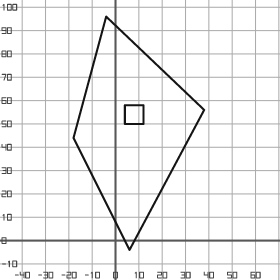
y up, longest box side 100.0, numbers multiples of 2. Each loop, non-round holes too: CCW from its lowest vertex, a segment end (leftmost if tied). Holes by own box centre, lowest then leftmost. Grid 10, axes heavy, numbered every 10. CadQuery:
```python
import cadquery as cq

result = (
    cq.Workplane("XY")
    .moveTo(6.0, -4.0)
    .lineTo(38.0, 56.0)
    .lineTo(-4.0, 96.0)
    .lineTo(-18.0, 44.0)
    .close()
    .moveTo(4.0, 50.0)
    .lineTo(12.0, 50.0)
    .lineTo(12.0, 58.0)
    .lineTo(4.0, 58.0)
    .close()
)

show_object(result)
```